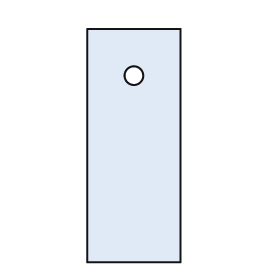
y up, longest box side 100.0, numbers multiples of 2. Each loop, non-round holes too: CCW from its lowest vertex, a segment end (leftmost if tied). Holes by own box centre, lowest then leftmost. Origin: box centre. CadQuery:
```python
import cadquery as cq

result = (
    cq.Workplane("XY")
    .moveTo(-20.0, -50.0)
    .lineTo(20.0, -50.0)
    .lineTo(20.0, 50.0)
    .lineTo(-20.0, 50.0)
    .close()
    .moveTo(0.0, 30.0)
    .circle(4.0)
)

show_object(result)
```